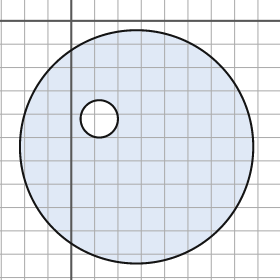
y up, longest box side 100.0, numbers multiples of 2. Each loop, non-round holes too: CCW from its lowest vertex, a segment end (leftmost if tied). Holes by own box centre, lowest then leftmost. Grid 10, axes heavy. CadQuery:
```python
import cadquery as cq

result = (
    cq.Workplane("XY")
    .moveTo(28.0, -54.0)
    .circle(50.0)
    .moveTo(12.0, -42.0)
    .circle(8.0)
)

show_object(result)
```